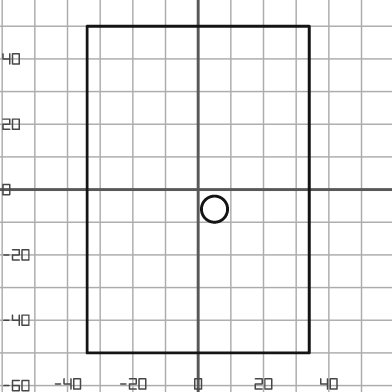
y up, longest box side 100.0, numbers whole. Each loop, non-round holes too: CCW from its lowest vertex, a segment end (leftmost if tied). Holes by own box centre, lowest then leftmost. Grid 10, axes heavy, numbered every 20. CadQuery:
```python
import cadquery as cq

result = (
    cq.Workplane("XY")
    .moveTo(-34.0, -50.0)
    .lineTo(34.0, -50.0)
    .lineTo(34.0, 50.0)
    .lineTo(-34.0, 50.0)
    .close()
    .moveTo(5.0, -6.0)
    .circle(4.0)
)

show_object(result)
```